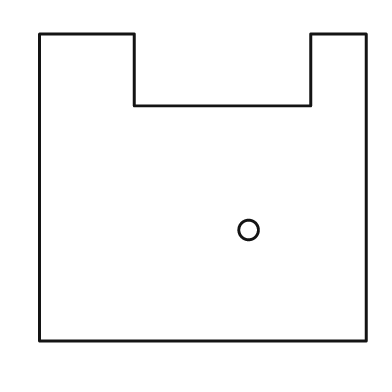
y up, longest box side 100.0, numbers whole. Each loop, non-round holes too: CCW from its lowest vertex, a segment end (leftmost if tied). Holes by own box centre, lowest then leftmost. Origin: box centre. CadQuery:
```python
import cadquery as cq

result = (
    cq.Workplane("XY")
    .moveTo(-50.0, -47.0)
    .lineTo(50.0, -47.0)
    .lineTo(50.0, 47.0)
    .lineTo(33.0, 47.0)
    .lineTo(33.0, 25.0)
    .lineTo(-21.0, 25.0)
    .lineTo(-21.0, 47.0)
    .lineTo(-50.0, 47.0)
    .close()
    .moveTo(14.0, -13.0)
    .circle(3.0)
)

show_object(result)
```